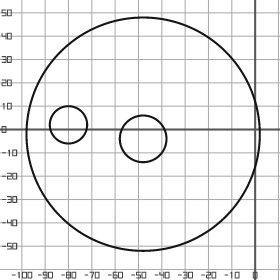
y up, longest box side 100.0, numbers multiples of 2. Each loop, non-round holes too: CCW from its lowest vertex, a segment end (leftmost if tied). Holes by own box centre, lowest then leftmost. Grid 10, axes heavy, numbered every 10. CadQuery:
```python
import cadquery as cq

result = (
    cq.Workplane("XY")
    .moveTo(-48.0, -2.0)
    .circle(50.0)
    .moveTo(-48.0, -4.0)
    .circle(10.0)
    .moveTo(-80.0, 2.0)
    .circle(8.0)
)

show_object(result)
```